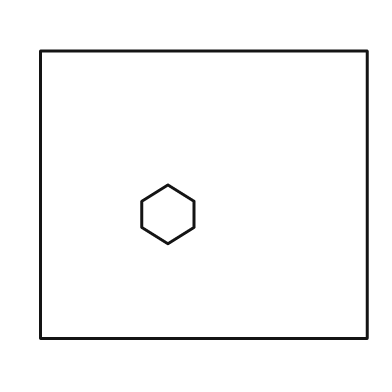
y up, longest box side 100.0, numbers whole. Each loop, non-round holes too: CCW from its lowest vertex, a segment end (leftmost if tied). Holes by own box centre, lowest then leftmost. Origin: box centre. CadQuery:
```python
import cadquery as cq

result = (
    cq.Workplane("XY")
    .moveTo(-50.0, -44.0)
    .lineTo(50.0, -44.0)
    .lineTo(50.0, 44.0)
    .lineTo(-50.0, 44.0)
    .close()
    .moveTo(-11.0, -15.0)
    .lineTo(-3.0, -10.0)
    .lineTo(-3.0, -2.0)
    .lineTo(-11.0, 3.0)
    .lineTo(-19.0, -2.0)
    .lineTo(-19.0, -10.0)
    .close()
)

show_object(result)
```